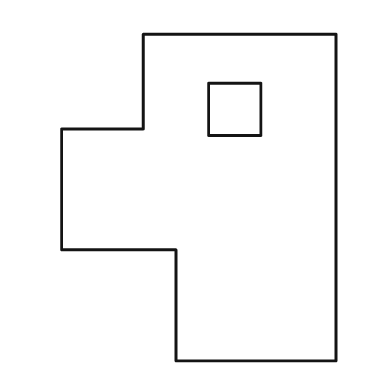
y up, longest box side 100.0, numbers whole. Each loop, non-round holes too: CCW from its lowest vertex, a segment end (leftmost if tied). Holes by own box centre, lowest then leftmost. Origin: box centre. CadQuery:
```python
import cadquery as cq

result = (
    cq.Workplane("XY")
    .moveTo(-7.0, -50.0)
    .lineTo(42.0, -50.0)
    .lineTo(42.0, 50.0)
    .lineTo(-17.0, 50.0)
    .lineTo(-17.0, 21.0)
    .lineTo(-42.0, 21.0)
    .lineTo(-42.0, -16.0)
    .lineTo(-7.0, -16.0)
    .close()
    .moveTo(3.0, 19.0)
    .lineTo(19.0, 19.0)
    .lineTo(19.0, 35.0)
    .lineTo(3.0, 35.0)
    .close()
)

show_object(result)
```